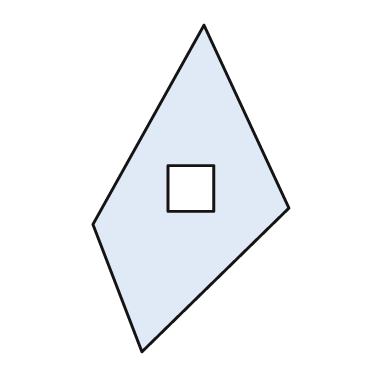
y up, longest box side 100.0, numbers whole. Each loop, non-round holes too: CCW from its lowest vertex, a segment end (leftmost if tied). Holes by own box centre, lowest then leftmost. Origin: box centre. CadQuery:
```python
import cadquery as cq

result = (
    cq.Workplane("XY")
    .moveTo(-15.0, -50.0)
    .lineTo(30.0, -6.0)
    .lineTo(4.0, 50.0)
    .lineTo(-30.0, -11.0)
    .close()
    .moveTo(-7.0, -7.0)
    .lineTo(7.0, -7.0)
    .lineTo(7.0, 7.0)
    .lineTo(-7.0, 7.0)
    .close()
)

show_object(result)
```